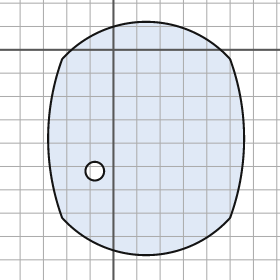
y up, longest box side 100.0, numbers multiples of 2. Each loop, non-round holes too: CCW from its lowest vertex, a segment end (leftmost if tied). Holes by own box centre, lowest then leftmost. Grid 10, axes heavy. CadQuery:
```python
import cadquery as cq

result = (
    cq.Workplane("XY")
    .moveTo(-22.0, -72.0)
    .threePointArc((14.0, -88.0), (50.0, -72.0))
    .threePointArc((56.0, -38.0), (50.0, -4.0))
    .threePointArc((14.0, 12.0), (-22.0, -4.0))
    .threePointArc((-28.0, -38.0), (-22.0, -72.0))
    .close()
    .moveTo(-8.0, -52.0)
    .circle(4.0)
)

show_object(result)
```